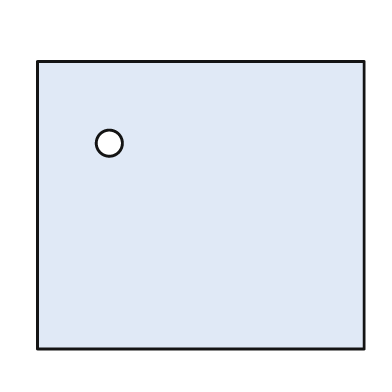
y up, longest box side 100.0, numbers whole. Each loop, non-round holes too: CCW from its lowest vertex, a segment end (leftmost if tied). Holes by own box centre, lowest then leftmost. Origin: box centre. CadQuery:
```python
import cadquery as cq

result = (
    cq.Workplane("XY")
    .moveTo(-50.0, -44.0)
    .lineTo(50.0, -44.0)
    .lineTo(50.0, 44.0)
    .lineTo(-50.0, 44.0)
    .close()
    .moveTo(-28.0, 19.0)
    .circle(4.0)
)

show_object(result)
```